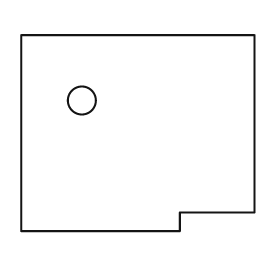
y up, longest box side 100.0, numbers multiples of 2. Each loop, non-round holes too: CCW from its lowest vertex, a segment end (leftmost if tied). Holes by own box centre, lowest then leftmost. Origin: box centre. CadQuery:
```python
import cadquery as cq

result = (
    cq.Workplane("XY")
    .moveTo(-50.0, -42.0)
    .lineTo(18.0, -42.0)
    .lineTo(18.0, -34.0)
    .lineTo(50.0, -34.0)
    .lineTo(50.0, 42.0)
    .lineTo(-50.0, 42.0)
    .close()
    .moveTo(-24.0, 14.0)
    .circle(6.0)
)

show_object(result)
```